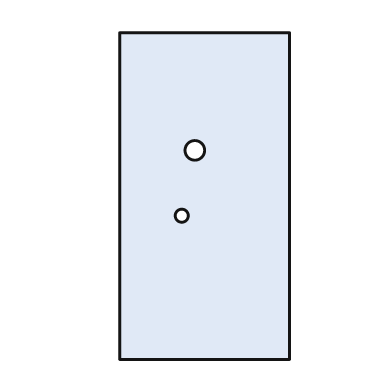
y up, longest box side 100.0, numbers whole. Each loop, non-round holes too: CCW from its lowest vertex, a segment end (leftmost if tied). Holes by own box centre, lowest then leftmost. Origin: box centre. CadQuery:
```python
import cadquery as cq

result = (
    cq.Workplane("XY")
    .moveTo(-26.0, -50.0)
    .lineTo(26.0, -50.0)
    .lineTo(26.0, 50.0)
    .lineTo(-26.0, 50.0)
    .close()
    .moveTo(-7.0, -6.0)
    .circle(2.0)
    .moveTo(-3.0, 14.0)
    .circle(3.0)
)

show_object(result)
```